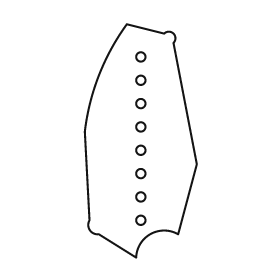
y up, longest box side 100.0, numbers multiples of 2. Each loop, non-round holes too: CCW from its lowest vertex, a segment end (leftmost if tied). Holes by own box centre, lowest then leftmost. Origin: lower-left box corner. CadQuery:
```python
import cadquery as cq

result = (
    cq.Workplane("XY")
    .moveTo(22.0, 0.0)
    .threePointArc((28.0, 10.0), (40.0, 10.0))
    .lineTo(48.0, 40.0)
    .lineTo(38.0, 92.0)
    .threePointArc((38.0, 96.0), (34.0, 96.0))
    .lineTo(18.0, 100.0)
    .threePointArc((6.0, 78.0), (0.0, 54.0))
    .lineTo(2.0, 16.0)
    .threePointArc((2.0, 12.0), (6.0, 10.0))
    .close()
    .moveTo(24.0, 16.0)
    .circle(2.0)
    .moveTo(24.0, 26.0)
    .circle(2.0)
    .moveTo(24.0, 36.0)
    .circle(2.0)
    .moveTo(24.0, 46.0)
    .circle(2.0)
    .moveTo(24.0, 56.0)
    .circle(2.0)
    .moveTo(24.0, 66.0)
    .circle(2.0)
    .moveTo(24.0, 76.0)
    .circle(2.0)
    .moveTo(24.0, 86.0)
    .circle(2.0)
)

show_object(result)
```